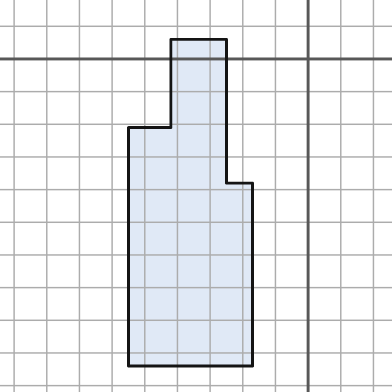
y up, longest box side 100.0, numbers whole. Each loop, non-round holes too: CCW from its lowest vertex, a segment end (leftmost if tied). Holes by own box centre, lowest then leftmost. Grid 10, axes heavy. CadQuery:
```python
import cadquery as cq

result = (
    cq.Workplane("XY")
    .moveTo(-55.0, -94.0)
    .lineTo(-17.0, -94.0)
    .lineTo(-17.0, -38.0)
    .lineTo(-25.0, -38.0)
    .lineTo(-25.0, 6.0)
    .lineTo(-42.0, 6.0)
    .lineTo(-42.0, -21.0)
    .lineTo(-55.0, -21.0)
    .close()
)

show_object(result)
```